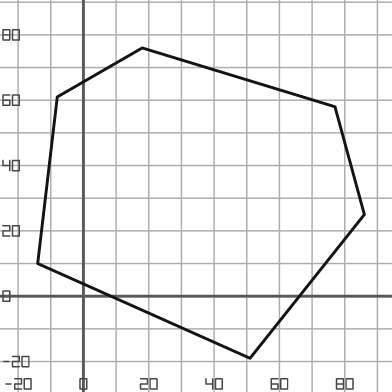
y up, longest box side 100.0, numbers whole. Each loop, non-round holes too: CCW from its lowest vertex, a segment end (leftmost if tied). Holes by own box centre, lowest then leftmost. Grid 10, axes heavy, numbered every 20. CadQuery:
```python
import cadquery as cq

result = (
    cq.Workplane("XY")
    .moveTo(51.0, -19.0)
    .lineTo(86.0, 25.0)
    .lineTo(77.0, 58.0)
    .lineTo(18.0, 76.0)
    .lineTo(-8.0, 61.0)
    .lineTo(-14.0, 10.0)
    .close()
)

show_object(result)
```